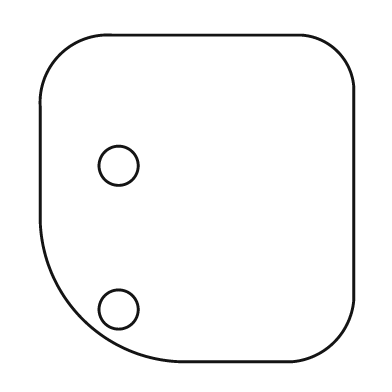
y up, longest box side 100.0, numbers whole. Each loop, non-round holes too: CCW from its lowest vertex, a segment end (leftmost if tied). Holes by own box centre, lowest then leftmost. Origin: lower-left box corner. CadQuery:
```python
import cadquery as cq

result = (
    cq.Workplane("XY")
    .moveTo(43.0, 0.0)
    .lineTo(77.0, 0.0)
    .threePointArc((90.0, 6.0), (96.0, 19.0))
    .lineTo(96.0, 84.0)
    .threePointArc((91.0, 95.0), (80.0, 100.0))
    .lineTo(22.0, 100.0)
    .threePointArc((6.0, 94.0), (0.0, 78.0))
    .lineTo(0.0, 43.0)
    .threePointArc((13.0, 13.0), (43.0, 0.0))
    .close()
    .moveTo(24.0, 16.0)
    .circle(6.0)
    .moveTo(24.0, 60.0)
    .circle(6.0)
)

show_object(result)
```